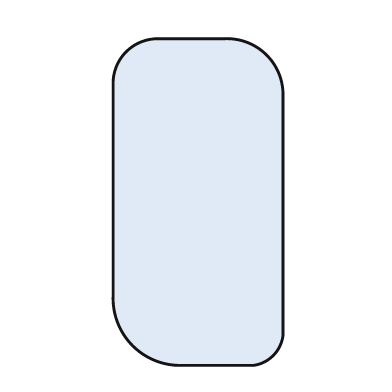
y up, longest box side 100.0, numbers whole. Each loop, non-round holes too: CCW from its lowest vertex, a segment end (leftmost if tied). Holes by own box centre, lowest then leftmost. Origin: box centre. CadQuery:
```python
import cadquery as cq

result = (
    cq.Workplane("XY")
    .moveTo(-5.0, -50.0)
    .lineTo(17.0, -50.0)
    .threePointArc((23.0, -47.0), (26.0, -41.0))
    .lineTo(26.0, 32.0)
    .threePointArc((21.0, 45.0), (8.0, 50.0))
    .lineTo(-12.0, 50.0)
    .threePointArc((-22.0, 46.0), (-26.0, 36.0))
    .lineTo(-26.0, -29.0)
    .threePointArc((-20.0, -44.0), (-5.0, -50.0))
    .close()
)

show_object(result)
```